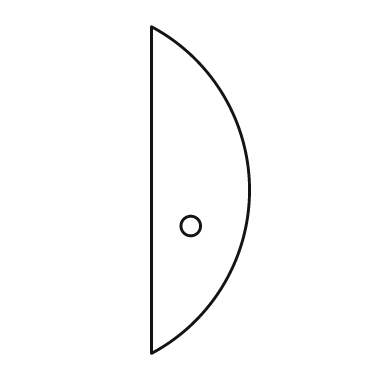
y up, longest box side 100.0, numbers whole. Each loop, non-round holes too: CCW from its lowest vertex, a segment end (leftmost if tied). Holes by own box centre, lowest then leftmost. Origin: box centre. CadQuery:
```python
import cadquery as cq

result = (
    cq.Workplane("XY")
    .moveTo(-15.0, -50.0)
    .threePointArc((15.0, 0.0), (-15.0, 50.0))
    .close()
    .moveTo(-3.0, -11.0)
    .circle(3.0)
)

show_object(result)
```